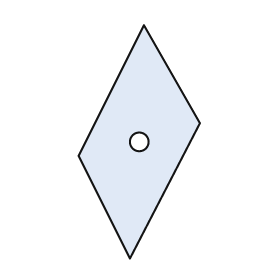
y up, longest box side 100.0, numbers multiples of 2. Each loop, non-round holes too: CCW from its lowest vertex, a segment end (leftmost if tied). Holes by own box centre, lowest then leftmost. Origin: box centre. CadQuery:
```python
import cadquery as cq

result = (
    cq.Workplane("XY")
    .moveTo(-4.0, -50.0)
    .lineTo(26.0, 8.0)
    .lineTo(2.0, 50.0)
    .lineTo(-26.0, -6.0)
    .close()
    .moveTo(0.0, 0.0)
    .circle(4.0)
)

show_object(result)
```